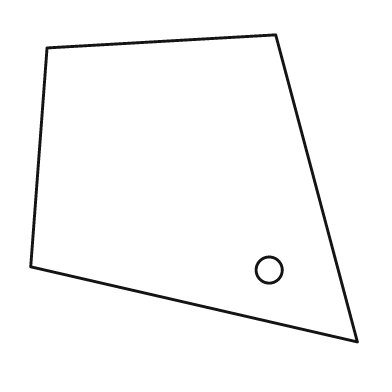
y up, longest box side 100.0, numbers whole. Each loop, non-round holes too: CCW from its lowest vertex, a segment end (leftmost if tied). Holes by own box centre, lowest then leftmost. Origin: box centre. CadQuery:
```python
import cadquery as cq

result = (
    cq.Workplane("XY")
    .moveTo(50.0, -47.0)
    .lineTo(25.0, 47.0)
    .lineTo(-45.0, 43.0)
    .lineTo(-50.0, -24.0)
    .close()
    .moveTo(23.0, -25.0)
    .circle(4.0)
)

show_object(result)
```